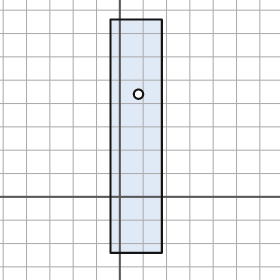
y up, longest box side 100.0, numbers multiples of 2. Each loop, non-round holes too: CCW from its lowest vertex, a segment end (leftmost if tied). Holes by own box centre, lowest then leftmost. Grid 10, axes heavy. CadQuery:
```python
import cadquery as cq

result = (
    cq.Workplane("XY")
    .moveTo(-4.0, -24.0)
    .lineTo(18.0, -24.0)
    .lineTo(18.0, 76.0)
    .lineTo(-4.0, 76.0)
    .close()
    .moveTo(8.0, 44.0)
    .circle(2.0)
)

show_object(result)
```